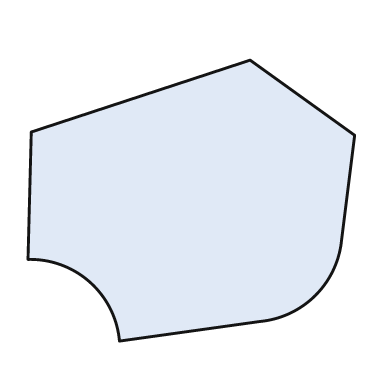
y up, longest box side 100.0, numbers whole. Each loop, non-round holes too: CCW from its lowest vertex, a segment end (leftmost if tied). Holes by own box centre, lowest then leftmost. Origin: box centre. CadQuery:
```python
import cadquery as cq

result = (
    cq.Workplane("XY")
    .moveTo(-22.0, -43.0)
    .lineTo(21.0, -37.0)
    .threePointArc((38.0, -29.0), (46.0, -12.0))
    .lineTo(50.0, 20.0)
    .lineTo(18.0, 43.0)
    .lineTo(-49.0, 21.0)
    .lineTo(-50.0, -18.0)
    .threePointArc((-31.0, -25.0), (-22.0, -43.0))
    .close()
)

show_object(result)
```